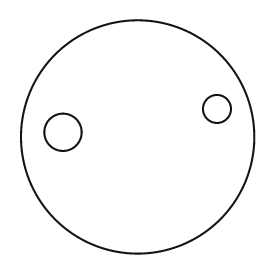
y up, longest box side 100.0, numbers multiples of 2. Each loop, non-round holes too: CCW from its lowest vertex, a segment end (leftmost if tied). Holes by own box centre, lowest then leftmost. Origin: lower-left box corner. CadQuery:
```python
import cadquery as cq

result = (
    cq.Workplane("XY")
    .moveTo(50.0, 50.0)
    .circle(50.0)
    .moveTo(18.0, 52.0)
    .circle(8.0)
    .moveTo(84.0, 62.0)
    .circle(6.0)
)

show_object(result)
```